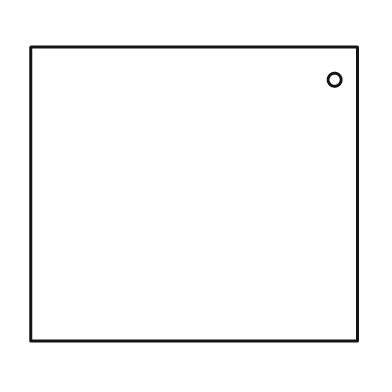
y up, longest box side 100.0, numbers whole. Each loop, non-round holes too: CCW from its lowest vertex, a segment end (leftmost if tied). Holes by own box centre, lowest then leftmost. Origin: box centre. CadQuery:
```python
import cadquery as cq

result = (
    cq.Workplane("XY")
    .moveTo(-50.0, -45.0)
    .lineTo(50.0, -45.0)
    .lineTo(50.0, 45.0)
    .lineTo(-50.0, 45.0)
    .close()
    .moveTo(43.0, 35.0)
    .circle(2.0)
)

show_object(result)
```